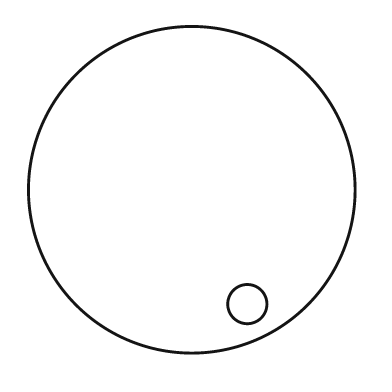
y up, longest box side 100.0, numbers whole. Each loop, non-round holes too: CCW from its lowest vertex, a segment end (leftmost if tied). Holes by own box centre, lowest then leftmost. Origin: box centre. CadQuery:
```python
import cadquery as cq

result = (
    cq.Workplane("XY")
    .moveTo(0.0, 0.0)
    .circle(50.0)
    .moveTo(17.0, -35.0)
    .circle(6.0)
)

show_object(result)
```